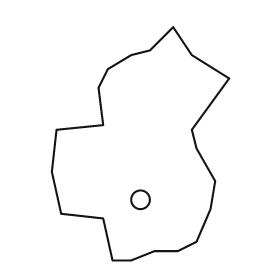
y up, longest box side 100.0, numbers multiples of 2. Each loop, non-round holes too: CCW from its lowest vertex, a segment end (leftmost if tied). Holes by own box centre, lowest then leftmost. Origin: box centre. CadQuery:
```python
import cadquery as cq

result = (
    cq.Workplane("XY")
    .moveTo(-12.0, -50.0)
    .lineTo(-4.0, -50.0)
    .lineTo(6.0, -46.0)
    .lineTo(16.0, -46.0)
    .lineTo(24.0, -42.0)
    .lineTo(30.0, -28.0)
    .lineTo(32.0, -16.0)
    .lineTo(24.0, -2.0)
    .lineTo(22.0, 6.0)
    .lineTo(38.0, 28.0)
    .lineTo(22.0, 38.0)
    .lineTo(14.0, 50.0)
    .lineTo(4.0, 40.0)
    .lineTo(-4.0, 38.0)
    .lineTo(-14.0, 32.0)
    .lineTo(-18.0, 24.0)
    .lineTo(-16.0, 8.0)
    .lineTo(-36.0, 6.0)
    .lineTo(-38.0, -12.0)
    .lineTo(-34.0, -30.0)
    .lineTo(-16.0, -32.0)
    .close()
    .moveTo(0.0, -24.0)
    .circle(4.0)
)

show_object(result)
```